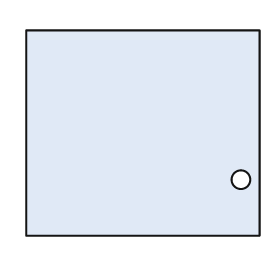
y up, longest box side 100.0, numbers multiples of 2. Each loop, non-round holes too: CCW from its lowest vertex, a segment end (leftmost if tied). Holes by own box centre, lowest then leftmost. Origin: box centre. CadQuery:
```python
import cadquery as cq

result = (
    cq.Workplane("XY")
    .moveTo(-50.0, -44.0)
    .lineTo(50.0, -44.0)
    .lineTo(50.0, 44.0)
    .lineTo(-50.0, 44.0)
    .close()
    .moveTo(42.0, -20.0)
    .circle(4.0)
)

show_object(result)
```